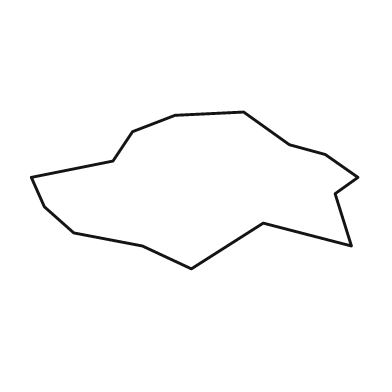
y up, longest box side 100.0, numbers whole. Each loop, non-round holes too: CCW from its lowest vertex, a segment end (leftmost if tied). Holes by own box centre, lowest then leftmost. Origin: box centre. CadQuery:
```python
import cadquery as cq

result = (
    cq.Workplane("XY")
    .moveTo(-1.0, -24.0)
    .lineTo(21.0, -10.0)
    .lineTo(48.0, -17.0)
    .lineTo(43.0, -1.0)
    .lineTo(50.0, 4.0)
    .lineTo(40.0, 11.0)
    .lineTo(29.0, 14.0)
    .lineTo(15.0, 24.0)
    .lineTo(-6.0, 23.0)
    .lineTo(-19.0, 18.0)
    .lineTo(-25.0, 9.0)
    .lineTo(-50.0, 4.0)
    .lineTo(-46.0, -5.0)
    .lineTo(-37.0, -13.0)
    .lineTo(-16.0, -17.0)
    .close()
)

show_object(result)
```